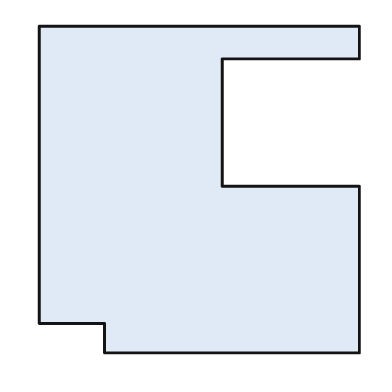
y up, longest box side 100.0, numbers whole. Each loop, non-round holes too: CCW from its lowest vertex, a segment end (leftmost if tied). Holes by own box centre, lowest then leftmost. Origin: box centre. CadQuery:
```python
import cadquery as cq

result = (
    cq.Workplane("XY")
    .moveTo(-29.0, -50.0)
    .lineTo(49.0, -50.0)
    .lineTo(49.0, 1.0)
    .lineTo(7.0, 1.0)
    .lineTo(7.0, 40.0)
    .lineTo(49.0, 40.0)
    .lineTo(49.0, 50.0)
    .lineTo(-49.0, 50.0)
    .lineTo(-49.0, -41.0)
    .lineTo(-29.0, -41.0)
    .close()
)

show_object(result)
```